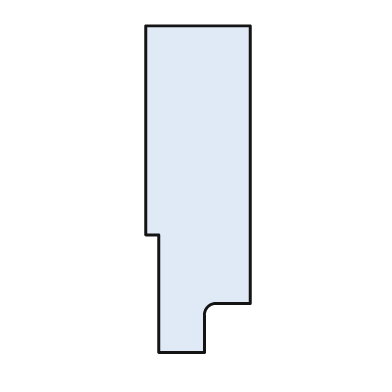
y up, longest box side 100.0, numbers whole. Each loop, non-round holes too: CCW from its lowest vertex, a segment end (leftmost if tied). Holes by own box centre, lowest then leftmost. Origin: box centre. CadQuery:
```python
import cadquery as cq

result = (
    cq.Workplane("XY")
    .moveTo(-12.0, -50.0)
    .lineTo(2.0, -50.0)
    .lineTo(2.0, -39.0)
    .threePointArc((3.0, -36.0), (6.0, -35.0))
    .lineTo(16.0, -35.0)
    .lineTo(16.0, 50.0)
    .lineTo(-16.0, 50.0)
    .lineTo(-16.0, -14.0)
    .lineTo(-12.0, -14.0)
    .close()
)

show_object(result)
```